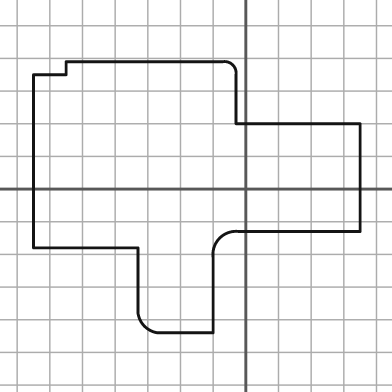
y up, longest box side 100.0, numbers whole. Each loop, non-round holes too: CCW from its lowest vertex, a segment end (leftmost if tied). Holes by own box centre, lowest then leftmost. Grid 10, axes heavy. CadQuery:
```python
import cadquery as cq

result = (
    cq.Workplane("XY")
    .moveTo(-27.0, -44.0)
    .lineTo(-10.0, -44.0)
    .lineTo(-10.0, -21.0)
    .threePointArc((-8.0, -15.0), (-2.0, -13.0))
    .lineTo(35.0, -13.0)
    .lineTo(35.0, 20.0)
    .lineTo(-3.0, 20.0)
    .lineTo(-3.0, 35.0)
    .threePointArc((-4.0, 38.0), (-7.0, 39.0))
    .lineTo(-55.0, 39.0)
    .lineTo(-55.0, 35.0)
    .lineTo(-65.0, 35.0)
    .lineTo(-65.0, -18.0)
    .lineTo(-33.0, -18.0)
    .lineTo(-33.0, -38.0)
    .threePointArc((-31.0, -42.0), (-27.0, -44.0))
    .close()
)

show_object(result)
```